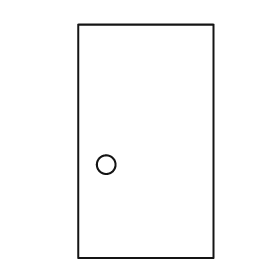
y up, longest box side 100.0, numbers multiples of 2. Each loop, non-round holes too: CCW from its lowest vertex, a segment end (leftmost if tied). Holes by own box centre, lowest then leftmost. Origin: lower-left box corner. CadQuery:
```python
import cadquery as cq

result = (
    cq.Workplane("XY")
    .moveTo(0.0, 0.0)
    .lineTo(58.0, 0.0)
    .lineTo(58.0, 100.0)
    .lineTo(0.0, 100.0)
    .close()
    .moveTo(12.0, 40.0)
    .circle(4.0)
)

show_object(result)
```